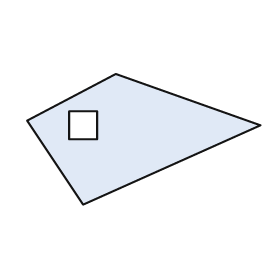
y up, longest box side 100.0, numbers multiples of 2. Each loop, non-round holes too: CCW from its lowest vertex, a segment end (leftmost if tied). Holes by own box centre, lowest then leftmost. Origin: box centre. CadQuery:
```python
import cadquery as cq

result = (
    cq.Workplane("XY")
    .moveTo(-26.0, -28.0)
    .lineTo(50.0, 6.0)
    .lineTo(-12.0, 28.0)
    .lineTo(-50.0, 8.0)
    .close()
    .moveTo(-32.0, 0.0)
    .lineTo(-20.0, 0.0)
    .lineTo(-20.0, 12.0)
    .lineTo(-32.0, 12.0)
    .close()
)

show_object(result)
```